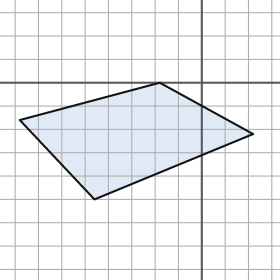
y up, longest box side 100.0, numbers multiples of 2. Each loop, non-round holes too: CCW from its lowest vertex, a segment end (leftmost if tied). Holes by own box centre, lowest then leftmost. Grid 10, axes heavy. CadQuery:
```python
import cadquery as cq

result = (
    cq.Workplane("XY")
    .moveTo(-46.0, -50.0)
    .lineTo(22.0, -22.0)
    .lineTo(-18.0, 0.0)
    .lineTo(-78.0, -16.0)
    .close()
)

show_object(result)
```